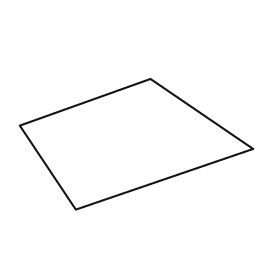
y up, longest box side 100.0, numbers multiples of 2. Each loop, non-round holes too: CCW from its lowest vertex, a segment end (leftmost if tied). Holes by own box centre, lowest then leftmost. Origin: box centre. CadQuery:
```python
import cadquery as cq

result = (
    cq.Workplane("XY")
    .moveTo(-26.0, -28.0)
    .lineTo(50.0, -2.0)
    .lineTo(6.0, 28.0)
    .lineTo(-50.0, 8.0)
    .close()
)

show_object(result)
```